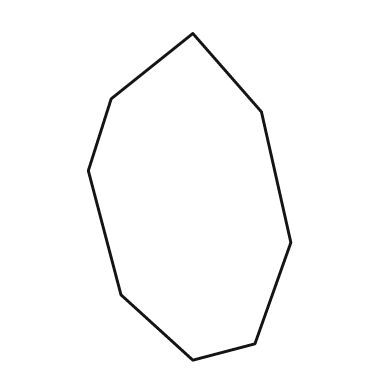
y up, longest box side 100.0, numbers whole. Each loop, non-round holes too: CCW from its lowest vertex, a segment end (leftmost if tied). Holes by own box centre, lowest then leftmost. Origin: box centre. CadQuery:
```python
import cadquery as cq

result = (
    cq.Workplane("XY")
    .moveTo(1.0, -50.0)
    .lineTo(20.0, -45.0)
    .lineTo(31.0, -14.0)
    .lineTo(22.0, 26.0)
    .lineTo(1.0, 50.0)
    .lineTo(-24.0, 30.0)
    .lineTo(-31.0, 8.0)
    .lineTo(-21.0, -30.0)
    .close()
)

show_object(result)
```